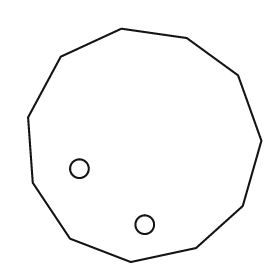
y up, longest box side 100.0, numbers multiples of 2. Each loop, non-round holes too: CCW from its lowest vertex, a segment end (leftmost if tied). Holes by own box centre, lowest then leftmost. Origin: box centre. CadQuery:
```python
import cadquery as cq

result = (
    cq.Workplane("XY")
    .moveTo(-6.0, -50.0)
    .lineTo(22.0, -44.0)
    .lineTo(42.0, -26.0)
    .lineTo(50.0, 2.0)
    .lineTo(40.0, 30.0)
    .lineTo(18.0, 46.0)
    .lineTo(-10.0, 50.0)
    .lineTo(-36.0, 38.0)
    .lineTo(-50.0, 12.0)
    .lineTo(-48.0, -16.0)
    .lineTo(-32.0, -40.0)
    .close()
    .moveTo(0.0, -34.0)
    .circle(4.0)
    .moveTo(-28.0, -10.0)
    .circle(4.0)
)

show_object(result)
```